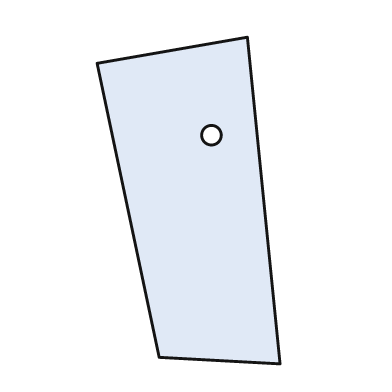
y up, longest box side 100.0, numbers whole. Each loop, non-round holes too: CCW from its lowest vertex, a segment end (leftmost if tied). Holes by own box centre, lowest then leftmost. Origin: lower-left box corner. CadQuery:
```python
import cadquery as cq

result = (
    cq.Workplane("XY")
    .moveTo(56.0, 0.0)
    .lineTo(46.0, 100.0)
    .lineTo(0.0, 92.0)
    .lineTo(19.0, 2.0)
    .close()
    .moveTo(35.0, 70.0)
    .circle(3.0)
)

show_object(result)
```